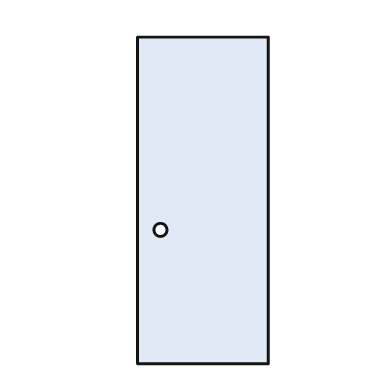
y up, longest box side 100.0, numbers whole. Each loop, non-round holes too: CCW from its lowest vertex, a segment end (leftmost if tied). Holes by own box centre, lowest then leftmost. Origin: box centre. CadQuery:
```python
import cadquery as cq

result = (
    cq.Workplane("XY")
    .moveTo(-20.0, -50.0)
    .lineTo(20.0, -50.0)
    .lineTo(20.0, 50.0)
    .lineTo(-20.0, 50.0)
    .close()
    .moveTo(-13.0, -9.0)
    .circle(2.0)
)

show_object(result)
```